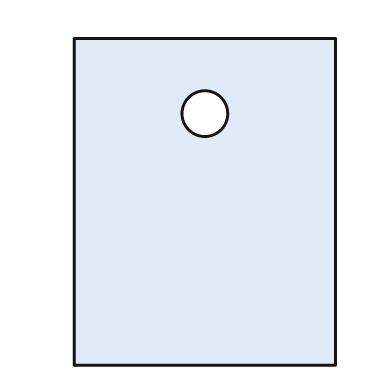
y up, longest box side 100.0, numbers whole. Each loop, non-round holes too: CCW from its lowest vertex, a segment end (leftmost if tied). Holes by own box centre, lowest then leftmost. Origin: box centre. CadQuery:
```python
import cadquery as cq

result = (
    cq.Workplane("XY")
    .moveTo(-40.0, -50.0)
    .lineTo(40.0, -50.0)
    .lineTo(40.0, 50.0)
    .lineTo(-40.0, 50.0)
    .close()
    .moveTo(0.0, 27.0)
    .circle(7.0)
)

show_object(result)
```